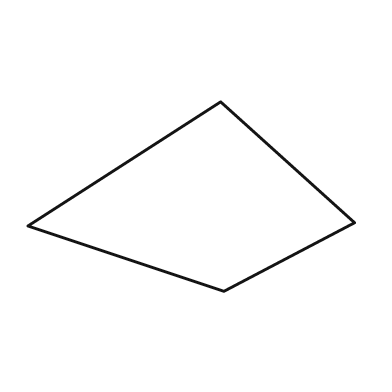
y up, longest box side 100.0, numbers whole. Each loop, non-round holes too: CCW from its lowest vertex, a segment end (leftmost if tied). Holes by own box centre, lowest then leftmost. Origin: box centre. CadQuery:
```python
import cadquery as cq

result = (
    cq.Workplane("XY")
    .moveTo(10.0, -29.0)
    .lineTo(50.0, -8.0)
    .lineTo(9.0, 29.0)
    .lineTo(-50.0, -9.0)
    .close()
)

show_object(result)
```